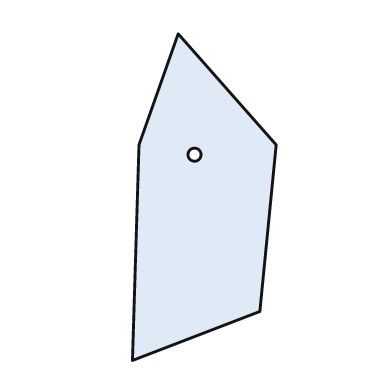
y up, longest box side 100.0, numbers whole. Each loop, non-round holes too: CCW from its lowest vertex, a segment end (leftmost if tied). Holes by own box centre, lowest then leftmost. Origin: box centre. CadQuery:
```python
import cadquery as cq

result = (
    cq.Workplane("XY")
    .moveTo(-22.0, -50.0)
    .lineTo(17.0, -35.0)
    .lineTo(22.0, 16.0)
    .lineTo(-8.0, 50.0)
    .lineTo(-20.0, 16.0)
    .close()
    .moveTo(-3.0, 13.0)
    .circle(2.0)
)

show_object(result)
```